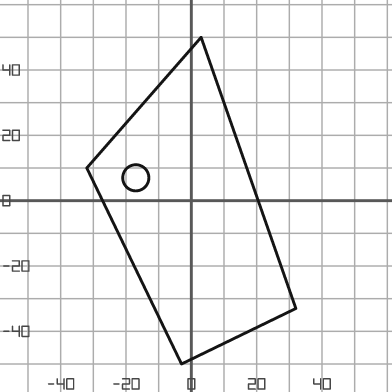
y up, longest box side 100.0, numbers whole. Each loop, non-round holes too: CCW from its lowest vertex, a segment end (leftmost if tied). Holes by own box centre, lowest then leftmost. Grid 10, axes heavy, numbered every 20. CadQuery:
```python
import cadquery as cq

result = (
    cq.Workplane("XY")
    .moveTo(-3.0, -50.0)
    .lineTo(32.0, -33.0)
    .lineTo(3.0, 50.0)
    .lineTo(-32.0, 10.0)
    .close()
    .moveTo(-17.0, 7.0)
    .circle(4.0)
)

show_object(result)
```